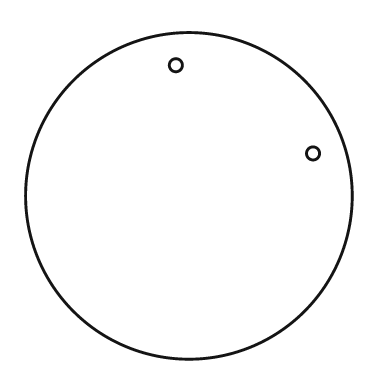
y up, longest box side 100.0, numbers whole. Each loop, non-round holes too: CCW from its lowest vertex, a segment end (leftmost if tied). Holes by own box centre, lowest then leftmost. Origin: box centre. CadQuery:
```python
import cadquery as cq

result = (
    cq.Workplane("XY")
    .moveTo(0.0, 0.0)
    .circle(50.0)
    .moveTo(38.0, 13.0)
    .circle(2.0)
    .moveTo(-4.0, 40.0)
    .circle(2.0)
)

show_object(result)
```